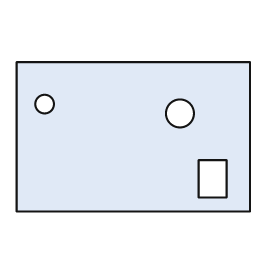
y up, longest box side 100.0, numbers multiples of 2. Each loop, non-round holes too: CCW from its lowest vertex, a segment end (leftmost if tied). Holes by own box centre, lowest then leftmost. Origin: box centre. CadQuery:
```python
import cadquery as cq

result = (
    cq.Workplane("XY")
    .moveTo(-50.0, -32.0)
    .lineTo(50.0, -32.0)
    .lineTo(50.0, 32.0)
    .lineTo(-50.0, 32.0)
    .close()
    .moveTo(28.0, -26.0)
    .lineTo(40.0, -26.0)
    .lineTo(40.0, -10.0)
    .lineTo(28.0, -10.0)
    .close()
    .moveTo(20.0, 10.0)
    .circle(6.0)
    .moveTo(-38.0, 14.0)
    .circle(4.0)
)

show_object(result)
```